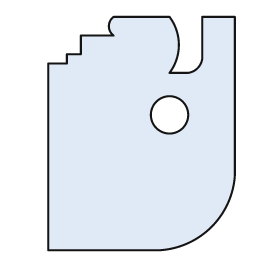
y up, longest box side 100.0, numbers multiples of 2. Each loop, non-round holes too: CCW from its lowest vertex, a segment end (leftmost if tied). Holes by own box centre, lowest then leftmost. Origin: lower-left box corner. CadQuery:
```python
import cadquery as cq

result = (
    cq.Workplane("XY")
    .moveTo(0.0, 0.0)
    .lineTo(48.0, 0.0)
    .threePointArc((70.0, 10.0), (80.0, 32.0))
    .lineTo(80.0, 100.0)
    .lineTo(66.0, 100.0)
    .lineTo(66.0, 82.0)
    .threePointArc((64.0, 78.0), (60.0, 76.0))
    .lineTo(52.0, 76.0)
    .threePointArc((56.0, 88.0), (52.0, 100.0))
    .lineTo(28.0, 100.0)
    .threePointArc((26.0, 96.0), (28.0, 92.0))
    .lineTo(14.0, 92.0)
    .lineTo(14.0, 84.0)
    .lineTo(8.0, 84.0)
    .lineTo(8.0, 80.0)
    .lineTo(0.0, 80.0)
    .close()
    .moveTo(52.0, 58.0)
    .circle(8.0)
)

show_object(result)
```